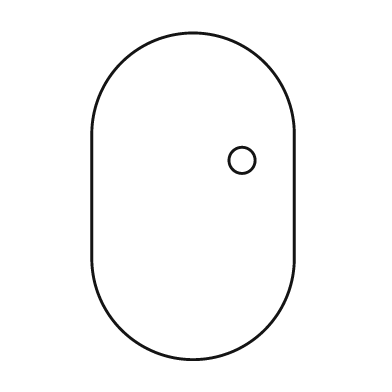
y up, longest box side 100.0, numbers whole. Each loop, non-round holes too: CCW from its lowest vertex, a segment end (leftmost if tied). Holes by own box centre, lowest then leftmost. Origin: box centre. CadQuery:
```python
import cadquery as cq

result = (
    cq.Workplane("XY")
    .moveTo(-31.0, -19.0)
    .threePointArc((0.0, -50.0), (31.0, -19.0))
    .lineTo(31.0, 19.0)
    .threePointArc((0.0, 50.0), (-31.0, 19.0))
    .close()
    .moveTo(15.0, 11.0)
    .circle(4.0)
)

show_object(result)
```